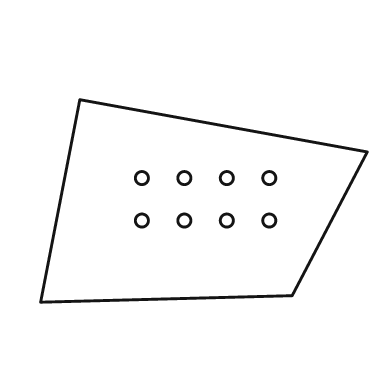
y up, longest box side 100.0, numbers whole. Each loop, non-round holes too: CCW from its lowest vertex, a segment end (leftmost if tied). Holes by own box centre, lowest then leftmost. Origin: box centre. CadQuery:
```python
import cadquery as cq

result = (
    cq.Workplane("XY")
    .moveTo(-50.0, -31.0)
    .lineTo(27.0, -29.0)
    .lineTo(50.0, 15.0)
    .lineTo(-38.0, 31.0)
    .close()
    .moveTo(-19.0, -6.0)
    .circle(2.0)
    .moveTo(-6.0, -6.0)
    .circle(2.0)
    .moveTo(7.0, -6.0)
    .circle(2.0)
    .moveTo(20.0, -6.0)
    .circle(2.0)
    .moveTo(-19.0, 7.0)
    .circle(2.0)
    .moveTo(-6.0, 7.0)
    .circle(2.0)
    .moveTo(7.0, 7.0)
    .circle(2.0)
    .moveTo(20.0, 7.0)
    .circle(2.0)
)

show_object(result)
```